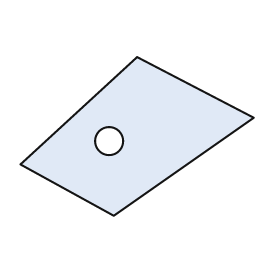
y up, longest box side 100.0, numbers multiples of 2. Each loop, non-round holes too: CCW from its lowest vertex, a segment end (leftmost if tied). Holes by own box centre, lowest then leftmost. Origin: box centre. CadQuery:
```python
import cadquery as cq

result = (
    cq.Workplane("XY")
    .moveTo(-10.0, -34.0)
    .lineTo(50.0, 8.0)
    .lineTo(0.0, 34.0)
    .lineTo(-50.0, -12.0)
    .close()
    .moveTo(-12.0, -2.0)
    .circle(6.0)
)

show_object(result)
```